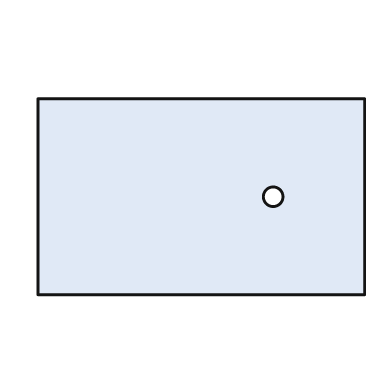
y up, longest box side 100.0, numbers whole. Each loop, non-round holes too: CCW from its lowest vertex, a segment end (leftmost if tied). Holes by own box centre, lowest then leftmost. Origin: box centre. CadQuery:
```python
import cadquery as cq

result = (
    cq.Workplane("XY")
    .moveTo(-50.0, -30.0)
    .lineTo(50.0, -30.0)
    .lineTo(50.0, 30.0)
    .lineTo(-50.0, 30.0)
    .close()
    .moveTo(22.0, 0.0)
    .circle(3.0)
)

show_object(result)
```